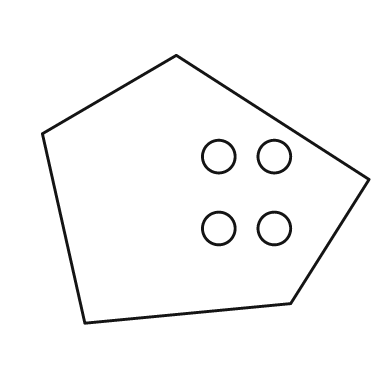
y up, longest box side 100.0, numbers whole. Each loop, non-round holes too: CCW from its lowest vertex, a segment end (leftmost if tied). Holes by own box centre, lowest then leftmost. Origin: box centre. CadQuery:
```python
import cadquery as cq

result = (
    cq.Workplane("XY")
    .moveTo(-37.0, -41.0)
    .lineTo(26.0, -35.0)
    .lineTo(50.0, 3.0)
    .lineTo(-9.0, 41.0)
    .lineTo(-50.0, 17.0)
    .close()
    .moveTo(4.0, -12.0)
    .circle(5.0)
    .moveTo(21.0, -12.0)
    .circle(5.0)
    .moveTo(4.0, 10.0)
    .circle(5.0)
    .moveTo(21.0, 10.0)
    .circle(5.0)
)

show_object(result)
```